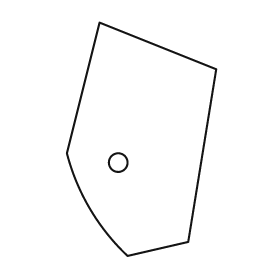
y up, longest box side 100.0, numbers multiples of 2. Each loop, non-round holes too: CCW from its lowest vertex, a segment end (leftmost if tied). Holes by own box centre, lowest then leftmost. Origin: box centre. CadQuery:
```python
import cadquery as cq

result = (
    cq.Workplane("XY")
    .moveTo(-6.0, -50.0)
    .lineTo(20.0, -44.0)
    .lineTo(32.0, 30.0)
    .lineTo(-18.0, 50.0)
    .lineTo(-32.0, -6.0)
    .threePointArc((-22.0, -30.0), (-6.0, -50.0))
    .close()
    .moveTo(-10.0, -10.0)
    .circle(4.0)
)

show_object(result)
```